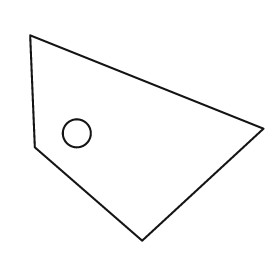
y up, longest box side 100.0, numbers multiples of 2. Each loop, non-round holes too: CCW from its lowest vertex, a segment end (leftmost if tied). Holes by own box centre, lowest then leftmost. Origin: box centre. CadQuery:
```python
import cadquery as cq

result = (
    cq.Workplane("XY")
    .moveTo(-2.0, -44.0)
    .lineTo(50.0, 4.0)
    .lineTo(-50.0, 44.0)
    .lineTo(-48.0, -4.0)
    .close()
    .moveTo(-30.0, 2.0)
    .circle(6.0)
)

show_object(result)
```